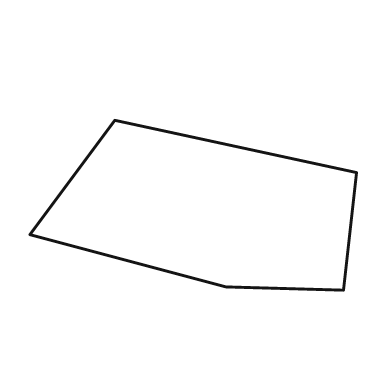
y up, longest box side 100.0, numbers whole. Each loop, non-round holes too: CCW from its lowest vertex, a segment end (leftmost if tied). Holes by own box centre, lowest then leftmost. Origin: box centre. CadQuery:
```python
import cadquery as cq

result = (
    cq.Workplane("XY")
    .moveTo(46.0, -26.0)
    .lineTo(50.0, 10.0)
    .lineTo(-24.0, 26.0)
    .lineTo(-50.0, -9.0)
    .lineTo(10.0, -25.0)
    .close()
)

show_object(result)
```